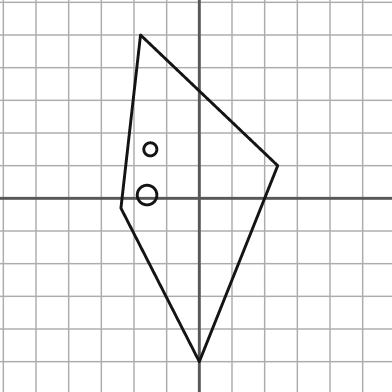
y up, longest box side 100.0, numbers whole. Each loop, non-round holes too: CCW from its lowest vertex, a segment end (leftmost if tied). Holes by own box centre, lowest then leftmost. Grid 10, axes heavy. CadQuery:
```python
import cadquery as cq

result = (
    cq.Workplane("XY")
    .moveTo(0.0, -50.0)
    .lineTo(24.0, 10.0)
    .lineTo(-18.0, 50.0)
    .lineTo(-24.0, -3.0)
    .close()
    .moveTo(-16.0, 1.0)
    .circle(3.0)
    .moveTo(-15.0, 15.0)
    .circle(2.0)
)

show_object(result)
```